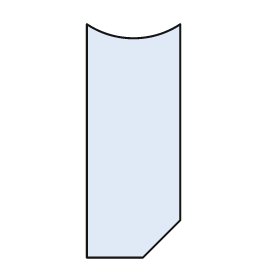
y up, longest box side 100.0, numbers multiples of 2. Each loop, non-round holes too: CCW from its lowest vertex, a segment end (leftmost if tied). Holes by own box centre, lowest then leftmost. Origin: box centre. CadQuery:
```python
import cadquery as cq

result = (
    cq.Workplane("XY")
    .moveTo(-20.0, -50.0)
    .lineTo(4.0, -50.0)
    .lineTo(20.0, -34.0)
    .lineTo(20.0, 50.0)
    .threePointArc((0.0, 44.0), (-20.0, 50.0))
    .close()
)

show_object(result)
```